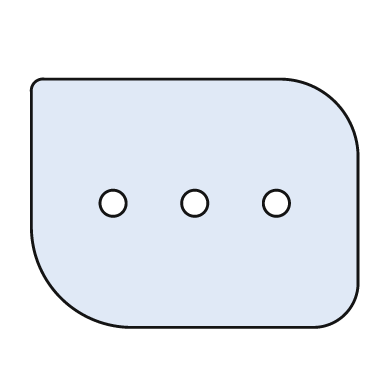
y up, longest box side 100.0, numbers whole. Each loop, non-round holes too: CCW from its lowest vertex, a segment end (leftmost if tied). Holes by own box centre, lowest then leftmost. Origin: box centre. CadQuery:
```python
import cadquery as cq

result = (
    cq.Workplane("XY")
    .moveTo(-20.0, -38.0)
    .lineTo(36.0, -38.0)
    .threePointArc((46.0, -34.0), (50.0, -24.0))
    .lineTo(50.0, 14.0)
    .threePointArc((43.0, 31.0), (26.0, 38.0))
    .lineTo(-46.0, 38.0)
    .threePointArc((-49.0, 37.0), (-50.0, 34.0))
    .lineTo(-50.0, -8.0)
    .threePointArc((-41.0, -29.0), (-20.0, -38.0))
    .close()
    .moveTo(-25.0, 0.0)
    .circle(4.0)
    .moveTo(0.0, 0.0)
    .circle(4.0)
    .moveTo(25.0, 0.0)
    .circle(4.0)
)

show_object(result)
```